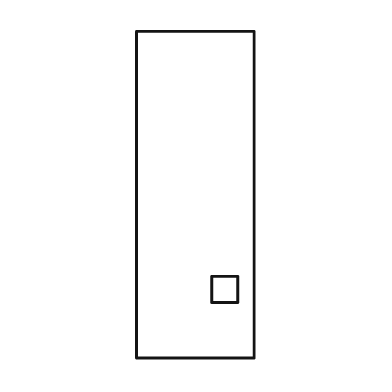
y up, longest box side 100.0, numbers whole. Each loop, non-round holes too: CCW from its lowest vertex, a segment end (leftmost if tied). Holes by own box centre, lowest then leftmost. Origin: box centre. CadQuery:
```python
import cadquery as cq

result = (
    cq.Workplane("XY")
    .moveTo(-18.0, -50.0)
    .lineTo(18.0, -50.0)
    .lineTo(18.0, 50.0)
    .lineTo(-18.0, 50.0)
    .close()
    .moveTo(5.0, -33.0)
    .lineTo(13.0, -33.0)
    .lineTo(13.0, -25.0)
    .lineTo(5.0, -25.0)
    .close()
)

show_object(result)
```